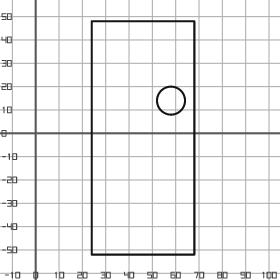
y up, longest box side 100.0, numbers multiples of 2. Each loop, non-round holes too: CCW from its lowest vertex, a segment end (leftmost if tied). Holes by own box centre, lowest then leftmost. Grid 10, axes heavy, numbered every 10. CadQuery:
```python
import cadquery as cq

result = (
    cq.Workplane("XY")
    .moveTo(24.0, -52.0)
    .lineTo(68.0, -52.0)
    .lineTo(68.0, 48.0)
    .lineTo(24.0, 48.0)
    .close()
    .moveTo(58.0, 14.0)
    .circle(6.0)
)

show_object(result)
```